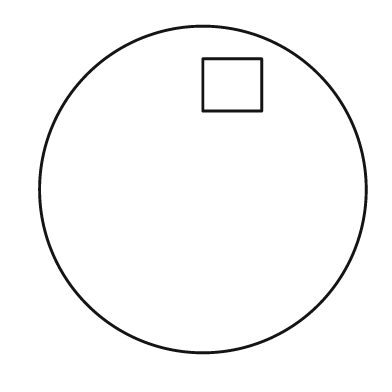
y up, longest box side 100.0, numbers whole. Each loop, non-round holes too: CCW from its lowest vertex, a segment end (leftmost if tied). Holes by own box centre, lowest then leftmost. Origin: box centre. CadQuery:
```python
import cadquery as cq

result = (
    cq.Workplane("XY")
    .moveTo(0.0, 0.0)
    .circle(50.0)
    .moveTo(0.0, 24.0)
    .lineTo(18.0, 24.0)
    .lineTo(18.0, 40.0)
    .lineTo(0.0, 40.0)
    .close()
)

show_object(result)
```